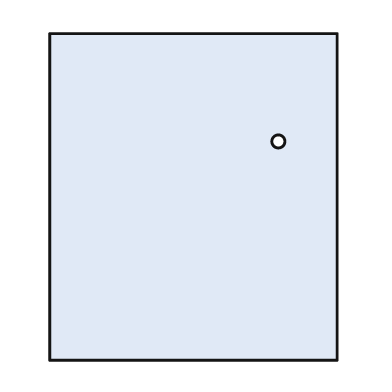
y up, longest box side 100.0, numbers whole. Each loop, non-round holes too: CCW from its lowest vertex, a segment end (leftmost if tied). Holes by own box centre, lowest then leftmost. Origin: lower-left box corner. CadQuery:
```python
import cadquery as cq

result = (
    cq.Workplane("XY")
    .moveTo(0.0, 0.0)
    .lineTo(88.0, 0.0)
    .lineTo(88.0, 100.0)
    .lineTo(0.0, 100.0)
    .close()
    .moveTo(70.0, 67.0)
    .circle(2.0)
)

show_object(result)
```